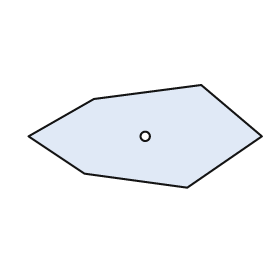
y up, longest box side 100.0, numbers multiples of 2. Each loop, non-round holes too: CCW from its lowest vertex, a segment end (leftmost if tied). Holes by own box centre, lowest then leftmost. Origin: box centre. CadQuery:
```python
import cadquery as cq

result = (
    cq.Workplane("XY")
    .moveTo(18.0, -22.0)
    .lineTo(50.0, 0.0)
    .lineTo(24.0, 22.0)
    .lineTo(-22.0, 16.0)
    .lineTo(-50.0, 0.0)
    .lineTo(-26.0, -16.0)
    .close()
    .moveTo(0.0, 0.0)
    .circle(2.0)
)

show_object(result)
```